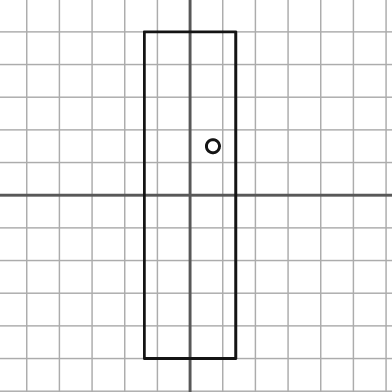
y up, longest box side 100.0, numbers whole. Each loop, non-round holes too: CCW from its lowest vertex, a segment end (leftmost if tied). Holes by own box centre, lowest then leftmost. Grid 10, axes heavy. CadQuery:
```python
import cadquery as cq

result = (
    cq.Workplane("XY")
    .moveTo(-14.0, -50.0)
    .lineTo(14.0, -50.0)
    .lineTo(14.0, 50.0)
    .lineTo(-14.0, 50.0)
    .close()
    .moveTo(7.0, 15.0)
    .circle(2.0)
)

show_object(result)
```